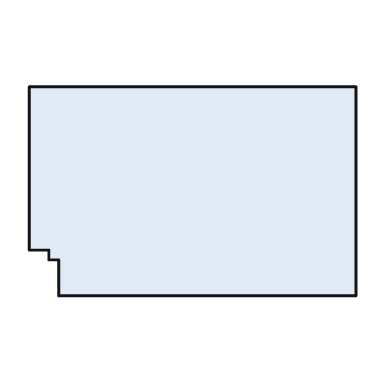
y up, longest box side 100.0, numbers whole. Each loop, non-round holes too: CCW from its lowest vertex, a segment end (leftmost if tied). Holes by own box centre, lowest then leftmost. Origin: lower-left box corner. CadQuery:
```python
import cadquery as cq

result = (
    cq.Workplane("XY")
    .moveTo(9.0, 0.0)
    .lineTo(100.0, 0.0)
    .lineTo(100.0, 64.0)
    .lineTo(0.0, 64.0)
    .lineTo(0.0, 14.0)
    .lineTo(6.0, 14.0)
    .lineTo(6.0, 11.0)
    .lineTo(9.0, 11.0)
    .close()
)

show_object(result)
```